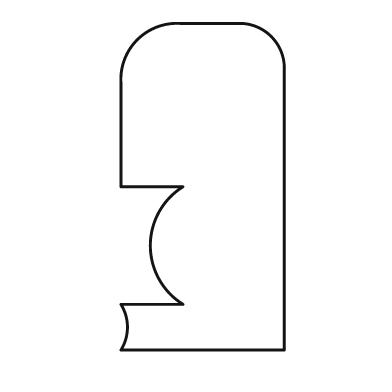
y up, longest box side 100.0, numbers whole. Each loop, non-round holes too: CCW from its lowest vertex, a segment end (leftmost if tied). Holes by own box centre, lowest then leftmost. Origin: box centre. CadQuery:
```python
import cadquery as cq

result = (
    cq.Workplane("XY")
    .moveTo(-25.0, -50.0)
    .lineTo(25.0, -50.0)
    .lineTo(25.0, 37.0)
    .threePointArc((21.0, 46.0), (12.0, 50.0))
    .lineTo(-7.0, 50.0)
    .threePointArc((-20.0, 45.0), (-25.0, 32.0))
    .lineTo(-25.0, 0.0)
    .lineTo(-6.0, 0.0)
    .threePointArc((-16.0, -18.0), (-6.0, -36.0))
    .lineTo(-25.0, -36.0)
    .threePointArc((-23.0, -43.0), (-25.0, -50.0))
    .close()
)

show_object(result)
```